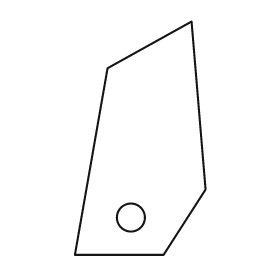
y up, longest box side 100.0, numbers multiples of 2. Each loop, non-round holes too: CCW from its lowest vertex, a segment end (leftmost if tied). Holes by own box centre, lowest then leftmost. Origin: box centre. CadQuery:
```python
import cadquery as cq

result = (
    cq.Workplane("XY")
    .moveTo(-28.0, -50.0)
    .lineTo(10.0, -50.0)
    .lineTo(28.0, -22.0)
    .lineTo(22.0, 50.0)
    .lineTo(-14.0, 30.0)
    .close()
    .moveTo(-4.0, -34.0)
    .circle(6.0)
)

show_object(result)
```